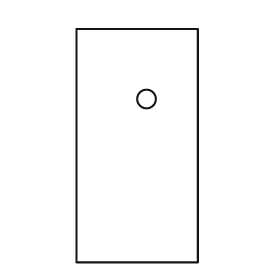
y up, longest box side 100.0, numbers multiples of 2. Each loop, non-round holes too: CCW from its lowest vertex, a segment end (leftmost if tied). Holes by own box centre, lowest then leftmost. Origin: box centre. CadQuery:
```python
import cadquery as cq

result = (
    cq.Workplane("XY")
    .moveTo(-26.0, -50.0)
    .lineTo(26.0, -50.0)
    .lineTo(26.0, 50.0)
    .lineTo(-26.0, 50.0)
    .close()
    .moveTo(4.0, 20.0)
    .circle(4.0)
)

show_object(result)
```